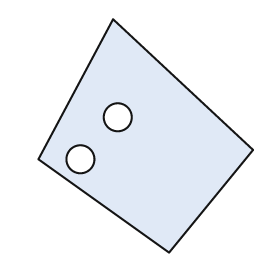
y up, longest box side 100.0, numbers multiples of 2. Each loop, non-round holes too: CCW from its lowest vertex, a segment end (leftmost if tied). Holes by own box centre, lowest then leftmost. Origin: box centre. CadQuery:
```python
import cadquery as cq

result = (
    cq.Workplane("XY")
    .moveTo(10.0, -50.0)
    .lineTo(46.0, -6.0)
    .lineTo(-14.0, 50.0)
    .lineTo(-46.0, -10.0)
    .close()
    .moveTo(-28.0, -10.0)
    .circle(6.0)
    .moveTo(-12.0, 8.0)
    .circle(6.0)
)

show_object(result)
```